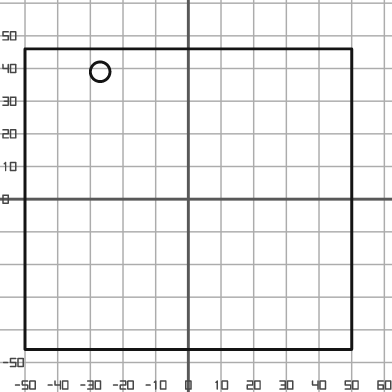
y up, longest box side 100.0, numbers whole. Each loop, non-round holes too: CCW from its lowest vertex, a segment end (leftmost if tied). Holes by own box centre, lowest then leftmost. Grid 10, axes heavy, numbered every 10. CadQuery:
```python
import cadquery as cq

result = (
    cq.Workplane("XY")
    .moveTo(-50.0, -46.0)
    .lineTo(50.0, -46.0)
    .lineTo(50.0, 46.0)
    .lineTo(-50.0, 46.0)
    .close()
    .moveTo(-27.0, 39.0)
    .circle(3.0)
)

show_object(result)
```